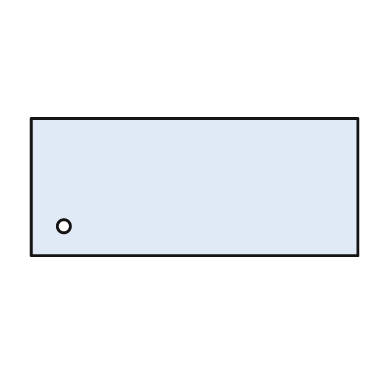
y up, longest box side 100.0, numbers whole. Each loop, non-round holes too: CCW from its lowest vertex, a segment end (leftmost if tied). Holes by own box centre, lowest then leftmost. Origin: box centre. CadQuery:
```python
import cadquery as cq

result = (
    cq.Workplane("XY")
    .moveTo(-50.0, -21.0)
    .lineTo(50.0, -21.0)
    .lineTo(50.0, 21.0)
    .lineTo(-50.0, 21.0)
    .close()
    .moveTo(-40.0, -12.0)
    .circle(2.0)
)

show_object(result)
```